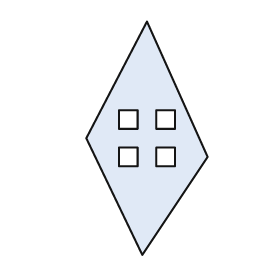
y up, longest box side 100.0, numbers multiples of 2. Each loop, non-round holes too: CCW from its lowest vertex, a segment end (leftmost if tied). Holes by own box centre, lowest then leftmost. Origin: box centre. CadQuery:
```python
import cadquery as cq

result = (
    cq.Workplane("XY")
    .moveTo(-2.0, -50.0)
    .lineTo(26.0, -8.0)
    .lineTo(0.0, 50.0)
    .lineTo(-26.0, 0.0)
    .close()
    .moveTo(-12.0, -12.0)
    .lineTo(-4.0, -12.0)
    .lineTo(-4.0, -4.0)
    .lineTo(-12.0, -4.0)
    .close()
    .moveTo(4.0, -12.0)
    .lineTo(12.0, -12.0)
    .lineTo(12.0, -4.0)
    .lineTo(4.0, -4.0)
    .close()
    .moveTo(-12.0, 4.0)
    .lineTo(-4.0, 4.0)
    .lineTo(-4.0, 12.0)
    .lineTo(-12.0, 12.0)
    .close()
    .moveTo(4.0, 4.0)
    .lineTo(12.0, 4.0)
    .lineTo(12.0, 12.0)
    .lineTo(4.0, 12.0)
    .close()
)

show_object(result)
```